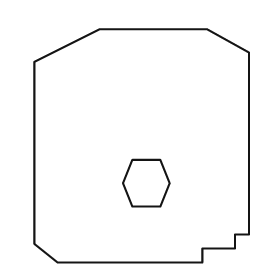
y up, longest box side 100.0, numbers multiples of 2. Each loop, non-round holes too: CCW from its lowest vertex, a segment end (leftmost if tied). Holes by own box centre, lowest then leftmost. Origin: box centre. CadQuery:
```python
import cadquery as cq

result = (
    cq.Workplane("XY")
    .moveTo(-36.0, -50.0)
    .lineTo(26.0, -50.0)
    .lineTo(26.0, -44.0)
    .lineTo(40.0, -44.0)
    .lineTo(40.0, -38.0)
    .lineTo(46.0, -38.0)
    .lineTo(46.0, 40.0)
    .lineTo(28.0, 50.0)
    .lineTo(-18.0, 50.0)
    .lineTo(-46.0, 36.0)
    .lineTo(-46.0, -42.0)
    .close()
    .moveTo(-4.0, -26.0)
    .lineTo(8.0, -26.0)
    .lineTo(12.0, -16.0)
    .lineTo(8.0, -6.0)
    .lineTo(-4.0, -6.0)
    .lineTo(-8.0, -16.0)
    .close()
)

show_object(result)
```